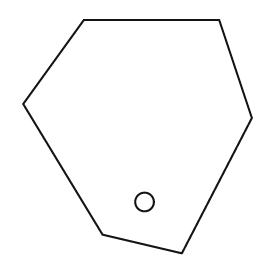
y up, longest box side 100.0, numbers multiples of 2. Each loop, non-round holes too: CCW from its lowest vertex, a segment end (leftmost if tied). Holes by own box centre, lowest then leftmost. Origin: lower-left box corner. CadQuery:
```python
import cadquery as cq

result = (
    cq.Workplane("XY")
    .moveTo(68.0, 0.0)
    .lineTo(98.0, 58.0)
    .lineTo(84.0, 100.0)
    .lineTo(26.0, 100.0)
    .lineTo(0.0, 64.0)
    .lineTo(34.0, 8.0)
    .close()
    .moveTo(52.0, 22.0)
    .circle(4.0)
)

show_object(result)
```